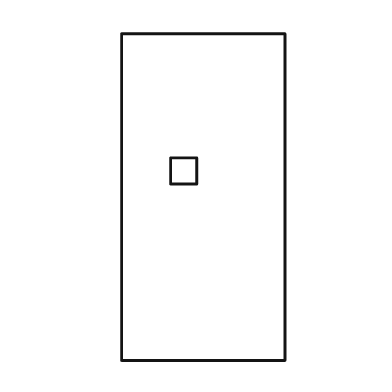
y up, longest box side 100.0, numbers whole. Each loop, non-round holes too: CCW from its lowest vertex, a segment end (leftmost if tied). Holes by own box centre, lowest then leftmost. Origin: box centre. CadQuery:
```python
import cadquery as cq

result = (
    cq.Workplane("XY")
    .moveTo(-25.0, -50.0)
    .lineTo(25.0, -50.0)
    .lineTo(25.0, 50.0)
    .lineTo(-25.0, 50.0)
    .close()
    .moveTo(-10.0, 4.0)
    .lineTo(-2.0, 4.0)
    .lineTo(-2.0, 12.0)
    .lineTo(-10.0, 12.0)
    .close()
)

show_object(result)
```